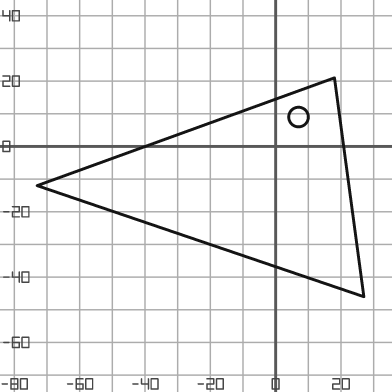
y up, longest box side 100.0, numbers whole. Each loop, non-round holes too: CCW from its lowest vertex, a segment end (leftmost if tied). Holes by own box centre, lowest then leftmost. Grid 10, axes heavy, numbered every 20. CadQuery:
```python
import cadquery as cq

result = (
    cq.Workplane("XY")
    .moveTo(27.0, -46.0)
    .lineTo(18.0, 21.0)
    .lineTo(-73.0, -12.0)
    .close()
    .moveTo(7.0, 9.0)
    .circle(3.0)
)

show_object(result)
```